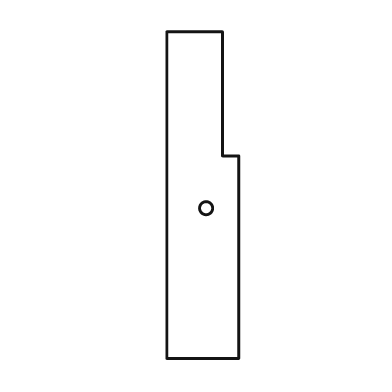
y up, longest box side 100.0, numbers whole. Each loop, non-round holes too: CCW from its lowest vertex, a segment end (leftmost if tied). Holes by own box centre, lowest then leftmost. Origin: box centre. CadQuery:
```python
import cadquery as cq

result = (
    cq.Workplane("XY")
    .moveTo(-11.0, -50.0)
    .lineTo(11.0, -50.0)
    .lineTo(11.0, 12.0)
    .lineTo(6.0, 12.0)
    .lineTo(6.0, 50.0)
    .lineTo(-11.0, 50.0)
    .close()
    .moveTo(1.0, -4.0)
    .circle(2.0)
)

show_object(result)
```